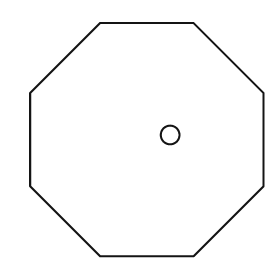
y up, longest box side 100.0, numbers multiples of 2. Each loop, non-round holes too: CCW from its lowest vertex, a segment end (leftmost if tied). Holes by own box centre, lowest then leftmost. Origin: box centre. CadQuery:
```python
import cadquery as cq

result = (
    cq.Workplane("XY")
    .moveTo(-20.0, -50.0)
    .lineTo(20.0, -50.0)
    .lineTo(50.0, -20.0)
    .lineTo(50.0, 20.0)
    .lineTo(20.0, 50.0)
    .lineTo(-20.0, 50.0)
    .lineTo(-50.0, 20.0)
    .lineTo(-50.0, -20.0)
    .close()
    .moveTo(10.0, 2.0)
    .circle(4.0)
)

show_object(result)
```